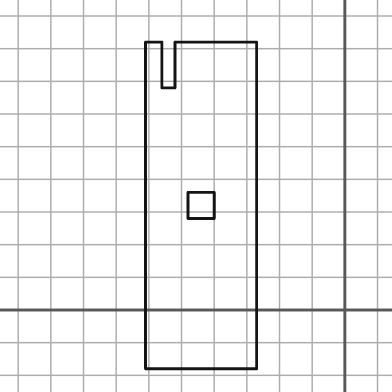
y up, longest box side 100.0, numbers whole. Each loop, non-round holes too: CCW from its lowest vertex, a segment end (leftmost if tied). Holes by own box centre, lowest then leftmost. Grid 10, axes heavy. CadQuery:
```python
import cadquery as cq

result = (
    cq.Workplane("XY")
    .moveTo(-61.0, -18.0)
    .lineTo(-27.0, -18.0)
    .lineTo(-27.0, 82.0)
    .lineTo(-52.0, 82.0)
    .lineTo(-52.0, 68.0)
    .lineTo(-56.0, 68.0)
    .lineTo(-56.0, 82.0)
    .lineTo(-61.0, 82.0)
    .close()
    .moveTo(-48.0, 28.0)
    .lineTo(-40.0, 28.0)
    .lineTo(-40.0, 36.0)
    .lineTo(-48.0, 36.0)
    .close()
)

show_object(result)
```